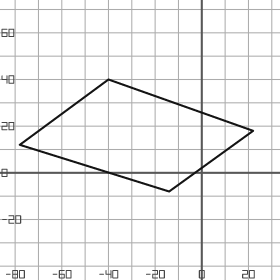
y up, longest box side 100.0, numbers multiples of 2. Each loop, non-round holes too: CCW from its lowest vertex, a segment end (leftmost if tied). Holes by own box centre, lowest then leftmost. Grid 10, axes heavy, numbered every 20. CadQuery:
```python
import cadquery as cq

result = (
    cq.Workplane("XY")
    .moveTo(-14.0, -8.0)
    .lineTo(22.0, 18.0)
    .lineTo(-40.0, 40.0)
    .lineTo(-78.0, 12.0)
    .close()
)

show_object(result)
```